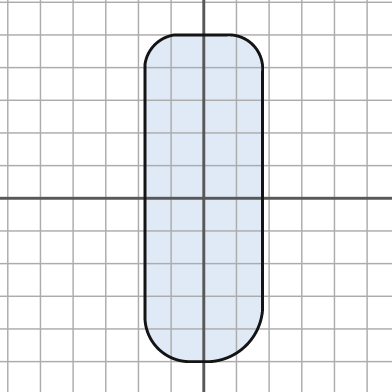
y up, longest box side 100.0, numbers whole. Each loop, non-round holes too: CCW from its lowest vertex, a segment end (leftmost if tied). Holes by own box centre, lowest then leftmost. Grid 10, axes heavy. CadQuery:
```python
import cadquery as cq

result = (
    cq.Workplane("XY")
    .moveTo(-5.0, -50.0)
    .lineTo(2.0, -50.0)
    .threePointArc((13.0, -45.0), (18.0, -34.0))
    .lineTo(18.0, 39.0)
    .threePointArc((15.0, 47.0), (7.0, 50.0))
    .lineTo(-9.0, 50.0)
    .threePointArc((-15.0, 47.0), (-18.0, 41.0))
    .lineTo(-18.0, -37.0)
    .threePointArc((-14.0, -46.0), (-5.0, -50.0))
    .close()
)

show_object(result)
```